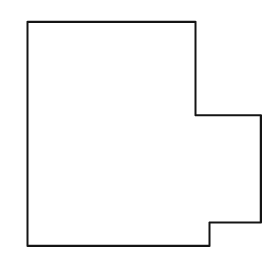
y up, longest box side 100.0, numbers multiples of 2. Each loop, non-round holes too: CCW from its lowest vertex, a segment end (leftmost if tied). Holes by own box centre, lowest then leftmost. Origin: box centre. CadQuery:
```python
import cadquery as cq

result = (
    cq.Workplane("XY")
    .moveTo(-50.0, -48.0)
    .lineTo(28.0, -48.0)
    .lineTo(28.0, -38.0)
    .lineTo(50.0, -38.0)
    .lineTo(50.0, 8.0)
    .lineTo(22.0, 8.0)
    .lineTo(22.0, 48.0)
    .lineTo(-50.0, 48.0)
    .close()
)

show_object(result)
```